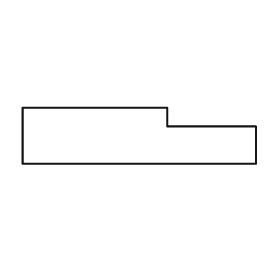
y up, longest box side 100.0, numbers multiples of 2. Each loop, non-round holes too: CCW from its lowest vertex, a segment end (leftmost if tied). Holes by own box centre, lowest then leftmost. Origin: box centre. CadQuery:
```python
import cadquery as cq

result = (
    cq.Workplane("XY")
    .moveTo(-50.0, -12.0)
    .lineTo(50.0, -12.0)
    .lineTo(50.0, 4.0)
    .lineTo(12.0, 4.0)
    .lineTo(12.0, 12.0)
    .lineTo(-50.0, 12.0)
    .close()
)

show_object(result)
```